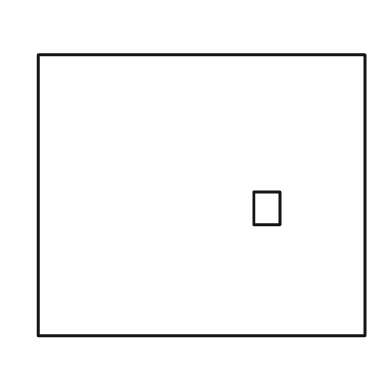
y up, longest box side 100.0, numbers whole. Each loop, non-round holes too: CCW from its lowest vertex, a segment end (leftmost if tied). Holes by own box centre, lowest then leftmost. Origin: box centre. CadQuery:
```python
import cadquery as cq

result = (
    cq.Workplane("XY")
    .moveTo(-50.0, -43.0)
    .lineTo(50.0, -43.0)
    .lineTo(50.0, 43.0)
    .lineTo(-50.0, 43.0)
    .close()
    .moveTo(16.0, -9.0)
    .lineTo(24.0, -9.0)
    .lineTo(24.0, 1.0)
    .lineTo(16.0, 1.0)
    .close()
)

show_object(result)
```